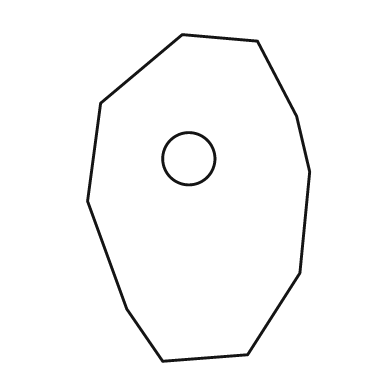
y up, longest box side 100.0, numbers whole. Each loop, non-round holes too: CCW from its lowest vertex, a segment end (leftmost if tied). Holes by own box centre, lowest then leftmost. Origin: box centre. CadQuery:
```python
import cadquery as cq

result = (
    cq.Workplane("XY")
    .moveTo(-11.0, -50.0)
    .lineTo(15.0, -48.0)
    .lineTo(31.0, -23.0)
    .lineTo(34.0, 8.0)
    .lineTo(30.0, 25.0)
    .lineTo(18.0, 48.0)
    .lineTo(-5.0, 50.0)
    .lineTo(-30.0, 29.0)
    .lineTo(-34.0, -1.0)
    .lineTo(-22.0, -34.0)
    .close()
    .moveTo(-3.0, 12.0)
    .circle(8.0)
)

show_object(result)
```